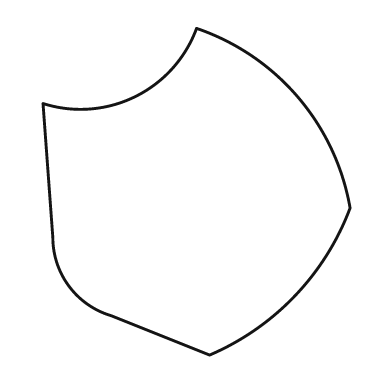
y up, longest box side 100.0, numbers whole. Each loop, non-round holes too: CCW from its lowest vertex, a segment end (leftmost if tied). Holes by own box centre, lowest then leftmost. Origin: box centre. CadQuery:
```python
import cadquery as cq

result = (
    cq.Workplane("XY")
    .moveTo(4.0, -50.0)
    .threePointArc((30.0, -32.0), (47.0, -5.0))
    .threePointArc((31.0, 29.0), (0.0, 50.0))
    .threePointArc((-19.0, 29.0), (-47.0, 27.0))
    .lineTo(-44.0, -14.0)
    .threePointArc((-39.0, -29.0), (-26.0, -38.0))
    .close()
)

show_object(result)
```